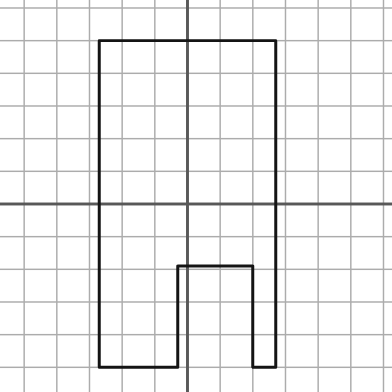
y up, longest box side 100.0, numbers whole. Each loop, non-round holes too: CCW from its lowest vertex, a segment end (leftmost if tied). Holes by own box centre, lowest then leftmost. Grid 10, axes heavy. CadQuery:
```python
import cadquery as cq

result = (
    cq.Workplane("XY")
    .moveTo(-27.0, -50.0)
    .lineTo(-3.0, -50.0)
    .lineTo(-3.0, -19.0)
    .lineTo(20.0, -19.0)
    .lineTo(20.0, -50.0)
    .lineTo(27.0, -50.0)
    .lineTo(27.0, 50.0)
    .lineTo(-27.0, 50.0)
    .close()
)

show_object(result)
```